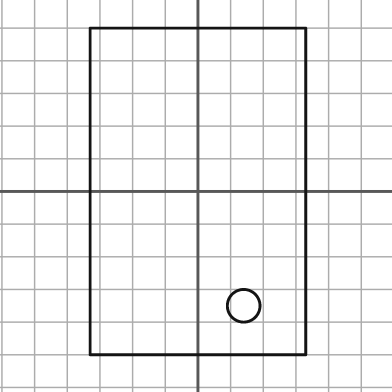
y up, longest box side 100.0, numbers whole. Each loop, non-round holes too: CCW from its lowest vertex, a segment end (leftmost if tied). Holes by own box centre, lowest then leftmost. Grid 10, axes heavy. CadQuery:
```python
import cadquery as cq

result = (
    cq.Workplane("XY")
    .moveTo(-33.0, -50.0)
    .lineTo(33.0, -50.0)
    .lineTo(33.0, 50.0)
    .lineTo(-33.0, 50.0)
    .close()
    .moveTo(14.0, -35.0)
    .circle(5.0)
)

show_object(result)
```